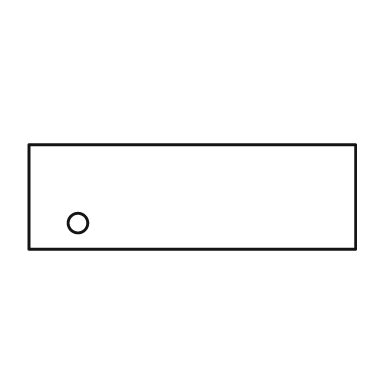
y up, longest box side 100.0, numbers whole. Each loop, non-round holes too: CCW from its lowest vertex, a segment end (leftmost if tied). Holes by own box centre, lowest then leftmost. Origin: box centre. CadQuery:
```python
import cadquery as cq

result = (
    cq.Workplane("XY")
    .moveTo(-50.0, -16.0)
    .lineTo(50.0, -16.0)
    .lineTo(50.0, 16.0)
    .lineTo(-50.0, 16.0)
    .close()
    .moveTo(-35.0, -8.0)
    .circle(3.0)
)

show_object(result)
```